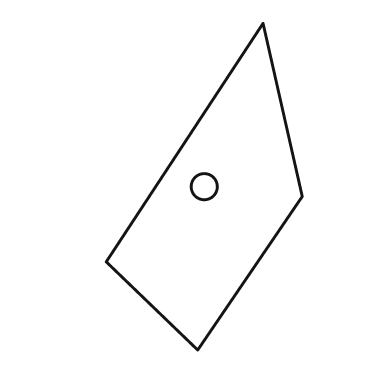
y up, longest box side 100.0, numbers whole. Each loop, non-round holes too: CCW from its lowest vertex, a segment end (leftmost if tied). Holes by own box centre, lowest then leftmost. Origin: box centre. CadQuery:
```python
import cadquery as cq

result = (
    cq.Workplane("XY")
    .moveTo(-2.0, -50.0)
    .lineTo(30.0, -3.0)
    .lineTo(18.0, 50.0)
    .lineTo(-30.0, -23.0)
    .close()
    .moveTo(0.0, 0.0)
    .circle(4.0)
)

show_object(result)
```